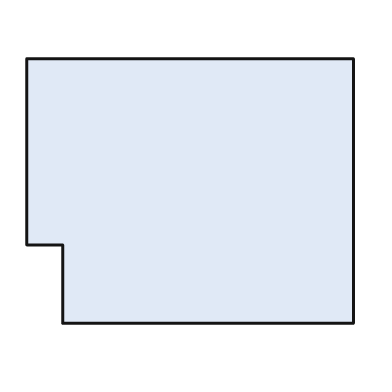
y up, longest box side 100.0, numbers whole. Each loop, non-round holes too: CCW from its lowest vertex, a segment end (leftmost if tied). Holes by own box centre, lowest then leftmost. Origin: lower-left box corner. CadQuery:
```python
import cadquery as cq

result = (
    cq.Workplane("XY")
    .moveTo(11.0, 0.0)
    .lineTo(100.0, 0.0)
    .lineTo(100.0, 81.0)
    .lineTo(0.0, 81.0)
    .lineTo(0.0, 24.0)
    .lineTo(11.0, 24.0)
    .close()
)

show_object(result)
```